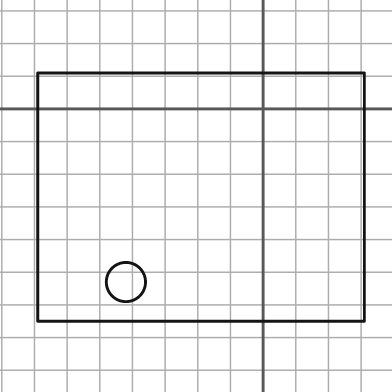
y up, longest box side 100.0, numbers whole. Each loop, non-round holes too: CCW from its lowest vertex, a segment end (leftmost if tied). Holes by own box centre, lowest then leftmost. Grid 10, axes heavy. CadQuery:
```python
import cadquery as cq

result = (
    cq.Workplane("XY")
    .moveTo(-69.0, -65.0)
    .lineTo(31.0, -65.0)
    .lineTo(31.0, 11.0)
    .lineTo(-69.0, 11.0)
    .close()
    .moveTo(-42.0, -53.0)
    .circle(6.0)
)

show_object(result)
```